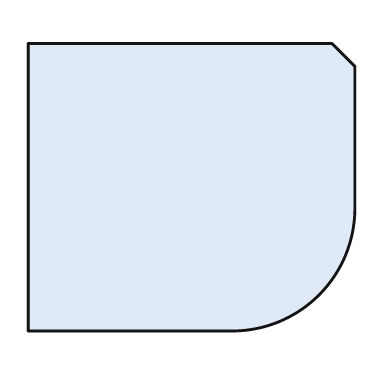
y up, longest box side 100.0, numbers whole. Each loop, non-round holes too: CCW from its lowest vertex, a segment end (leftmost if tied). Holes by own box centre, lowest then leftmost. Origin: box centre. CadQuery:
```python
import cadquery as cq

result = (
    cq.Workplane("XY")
    .moveTo(-50.0, -44.0)
    .lineTo(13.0, -44.0)
    .threePointArc((39.0, -33.0), (50.0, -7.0))
    .lineTo(50.0, 37.0)
    .lineTo(43.0, 44.0)
    .lineTo(-50.0, 44.0)
    .close()
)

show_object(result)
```